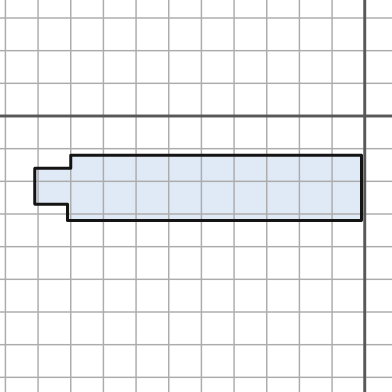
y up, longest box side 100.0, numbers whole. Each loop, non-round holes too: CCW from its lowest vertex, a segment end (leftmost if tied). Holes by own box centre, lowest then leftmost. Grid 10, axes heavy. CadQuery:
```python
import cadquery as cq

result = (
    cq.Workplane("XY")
    .moveTo(-91.0, -32.0)
    .lineTo(-1.0, -32.0)
    .lineTo(-1.0, -12.0)
    .lineTo(-90.0, -12.0)
    .lineTo(-90.0, -16.0)
    .lineTo(-101.0, -16.0)
    .lineTo(-101.0, -27.0)
    .lineTo(-91.0, -27.0)
    .close()
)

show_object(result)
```